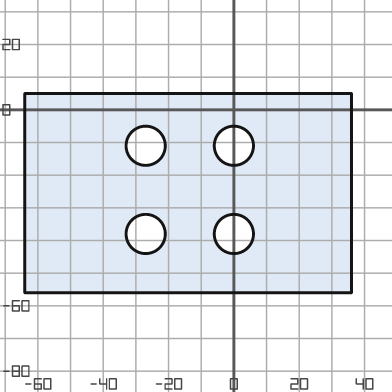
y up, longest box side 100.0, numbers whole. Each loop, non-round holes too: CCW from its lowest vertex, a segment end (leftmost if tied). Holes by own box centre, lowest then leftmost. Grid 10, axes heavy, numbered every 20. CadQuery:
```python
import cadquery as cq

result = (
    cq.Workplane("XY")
    .moveTo(-64.0, -56.0)
    .lineTo(36.0, -56.0)
    .lineTo(36.0, 5.0)
    .lineTo(-64.0, 5.0)
    .close()
    .moveTo(-27.0, -38.0)
    .circle(6.0)
    .moveTo(0.0, -38.0)
    .circle(6.0)
    .moveTo(-27.0, -11.0)
    .circle(6.0)
    .moveTo(0.0, -11.0)
    .circle(6.0)
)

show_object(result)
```